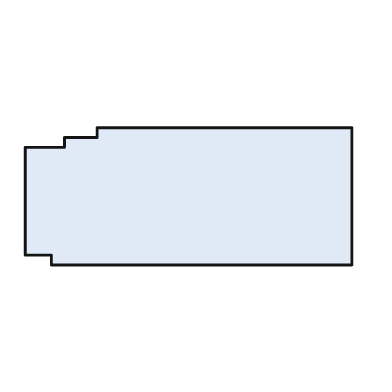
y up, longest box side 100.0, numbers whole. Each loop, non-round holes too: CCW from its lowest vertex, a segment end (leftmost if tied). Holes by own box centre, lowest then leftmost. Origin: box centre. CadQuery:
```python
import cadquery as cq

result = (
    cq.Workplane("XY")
    .moveTo(-42.0, -21.0)
    .lineTo(50.0, -21.0)
    .lineTo(50.0, 21.0)
    .lineTo(-28.0, 21.0)
    .lineTo(-28.0, 18.0)
    .lineTo(-38.0, 18.0)
    .lineTo(-38.0, 15.0)
    .lineTo(-50.0, 15.0)
    .lineTo(-50.0, -18.0)
    .lineTo(-42.0, -18.0)
    .close()
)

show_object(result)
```